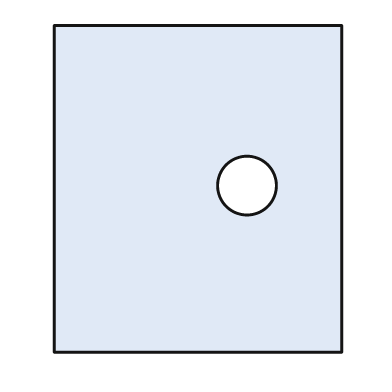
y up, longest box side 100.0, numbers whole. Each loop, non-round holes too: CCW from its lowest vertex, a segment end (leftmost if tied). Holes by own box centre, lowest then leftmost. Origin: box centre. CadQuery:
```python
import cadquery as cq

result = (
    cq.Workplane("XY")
    .moveTo(-44.0, -50.0)
    .lineTo(44.0, -50.0)
    .lineTo(44.0, 50.0)
    .lineTo(-44.0, 50.0)
    .close()
    .moveTo(15.0, 1.0)
    .circle(9.0)
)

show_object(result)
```